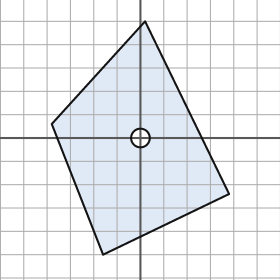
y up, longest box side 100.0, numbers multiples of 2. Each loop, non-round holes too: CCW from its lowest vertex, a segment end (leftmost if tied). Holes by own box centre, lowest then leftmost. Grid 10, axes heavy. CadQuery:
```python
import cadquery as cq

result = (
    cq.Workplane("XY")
    .moveTo(-16.0, -50.0)
    .lineTo(38.0, -24.0)
    .lineTo(2.0, 50.0)
    .lineTo(-38.0, 6.0)
    .close()
    .moveTo(0.0, 0.0)
    .circle(4.0)
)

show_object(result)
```